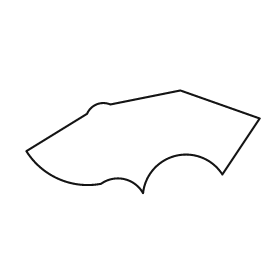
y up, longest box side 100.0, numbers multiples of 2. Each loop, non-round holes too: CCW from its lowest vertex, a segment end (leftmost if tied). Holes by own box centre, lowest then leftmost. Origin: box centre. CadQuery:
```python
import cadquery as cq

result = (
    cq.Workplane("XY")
    .moveTo(0.0, -22.0)
    .threePointArc((14.0, -6.0), (34.0, -14.0))
    .lineTo(50.0, 10.0)
    .lineTo(16.0, 22.0)
    .lineTo(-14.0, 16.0)
    .threePointArc((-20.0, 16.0), (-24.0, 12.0))
    .lineTo(-50.0, -4.0)
    .threePointArc((-36.0, -16.0), (-18.0, -18.0))
    .threePointArc((-8.0, -16.0), (0.0, -22.0))
    .close()
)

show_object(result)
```